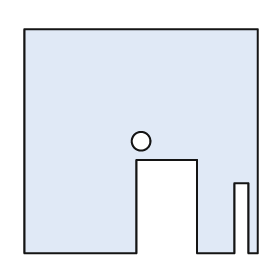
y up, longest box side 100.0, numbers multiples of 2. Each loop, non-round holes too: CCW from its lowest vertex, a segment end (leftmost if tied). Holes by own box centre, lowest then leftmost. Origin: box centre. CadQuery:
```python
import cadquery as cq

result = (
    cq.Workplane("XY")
    .moveTo(-50.0, -48.0)
    .lineTo(-2.0, -48.0)
    .lineTo(-2.0, -8.0)
    .lineTo(24.0, -8.0)
    .lineTo(24.0, -48.0)
    .lineTo(40.0, -48.0)
    .lineTo(40.0, -18.0)
    .lineTo(46.0, -18.0)
    .lineTo(46.0, -48.0)
    .lineTo(50.0, -48.0)
    .lineTo(50.0, 48.0)
    .lineTo(-50.0, 48.0)
    .close()
    .moveTo(0.0, 0.0)
    .circle(4.0)
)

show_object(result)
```